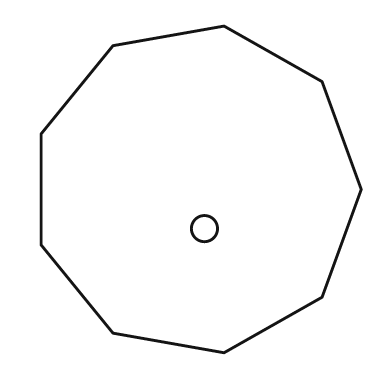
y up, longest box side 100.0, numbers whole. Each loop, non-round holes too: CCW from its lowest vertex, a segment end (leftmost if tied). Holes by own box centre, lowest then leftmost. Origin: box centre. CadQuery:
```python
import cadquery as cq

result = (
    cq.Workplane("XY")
    .moveTo(7.0, -50.0)
    .lineTo(37.0, -33.0)
    .lineTo(49.0, 0.0)
    .lineTo(37.0, 33.0)
    .lineTo(7.0, 50.0)
    .lineTo(-27.0, 44.0)
    .lineTo(-49.0, 17.0)
    .lineTo(-49.0, -17.0)
    .lineTo(-27.0, -44.0)
    .close()
    .moveTo(1.0, -12.0)
    .circle(4.0)
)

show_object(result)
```